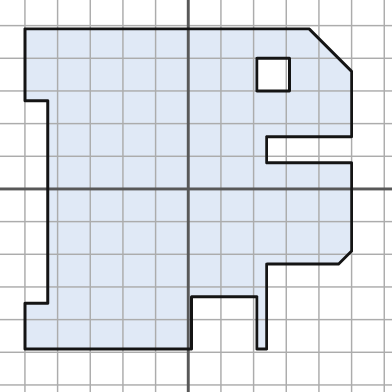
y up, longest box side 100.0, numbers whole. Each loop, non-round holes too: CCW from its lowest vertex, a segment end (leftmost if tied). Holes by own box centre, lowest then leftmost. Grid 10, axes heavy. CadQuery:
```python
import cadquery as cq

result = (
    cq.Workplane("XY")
    .moveTo(-50.0, -49.0)
    .lineTo(1.0, -49.0)
    .lineTo(1.0, -33.0)
    .lineTo(21.0, -33.0)
    .lineTo(21.0, -49.0)
    .lineTo(24.0, -49.0)
    .lineTo(24.0, -23.0)
    .lineTo(46.0, -23.0)
    .lineTo(50.0, -19.0)
    .lineTo(50.0, 8.0)
    .lineTo(24.0, 8.0)
    .lineTo(24.0, 16.0)
    .lineTo(50.0, 16.0)
    .lineTo(50.0, 36.0)
    .lineTo(37.0, 49.0)
    .lineTo(-50.0, 49.0)
    .lineTo(-50.0, 27.0)
    .lineTo(-43.0, 27.0)
    .lineTo(-43.0, -35.0)
    .lineTo(-50.0, -35.0)
    .close()
    .moveTo(21.0, 30.0)
    .lineTo(31.0, 30.0)
    .lineTo(31.0, 40.0)
    .lineTo(21.0, 40.0)
    .close()
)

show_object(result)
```